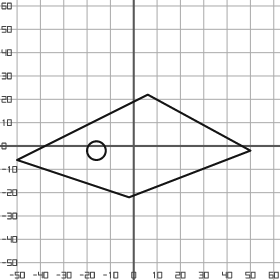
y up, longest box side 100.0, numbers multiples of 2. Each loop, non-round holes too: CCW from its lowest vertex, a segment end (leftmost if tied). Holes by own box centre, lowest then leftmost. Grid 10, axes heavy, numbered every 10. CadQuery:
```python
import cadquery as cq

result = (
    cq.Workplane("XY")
    .moveTo(-2.0, -22.0)
    .lineTo(50.0, -2.0)
    .lineTo(6.0, 22.0)
    .lineTo(-50.0, -6.0)
    .close()
    .moveTo(-16.0, -2.0)
    .circle(4.0)
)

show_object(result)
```